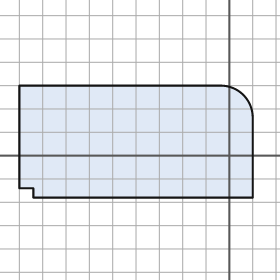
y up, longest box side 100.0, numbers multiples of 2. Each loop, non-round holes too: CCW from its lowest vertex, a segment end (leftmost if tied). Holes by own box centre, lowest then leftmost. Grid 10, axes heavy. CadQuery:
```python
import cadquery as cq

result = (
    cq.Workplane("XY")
    .moveTo(-84.0, -18.0)
    .lineTo(10.0, -18.0)
    .lineTo(10.0, 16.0)
    .threePointArc((6.0, 26.0), (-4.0, 30.0))
    .lineTo(-90.0, 30.0)
    .lineTo(-90.0, -14.0)
    .lineTo(-84.0, -14.0)
    .close()
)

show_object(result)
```